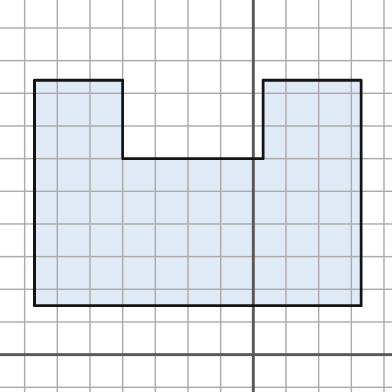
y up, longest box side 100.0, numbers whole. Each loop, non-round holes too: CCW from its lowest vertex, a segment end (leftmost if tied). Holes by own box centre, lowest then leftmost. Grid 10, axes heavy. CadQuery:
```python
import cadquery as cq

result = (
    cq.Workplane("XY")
    .moveTo(-67.0, 15.0)
    .lineTo(33.0, 15.0)
    .lineTo(33.0, 84.0)
    .lineTo(3.0, 84.0)
    .lineTo(3.0, 60.0)
    .lineTo(-40.0, 60.0)
    .lineTo(-40.0, 84.0)
    .lineTo(-67.0, 84.0)
    .close()
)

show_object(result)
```